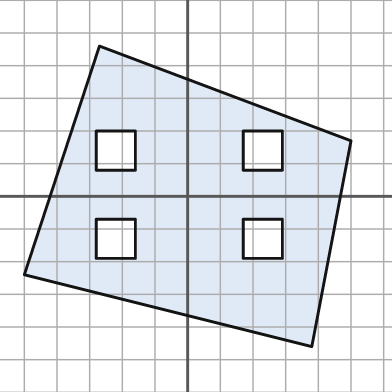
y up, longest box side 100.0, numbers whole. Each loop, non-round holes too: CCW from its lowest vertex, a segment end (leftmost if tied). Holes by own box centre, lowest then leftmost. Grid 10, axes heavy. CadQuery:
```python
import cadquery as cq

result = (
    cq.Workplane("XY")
    .moveTo(38.0, -46.0)
    .lineTo(50.0, 17.0)
    .lineTo(-27.0, 46.0)
    .lineTo(-50.0, -24.0)
    .close()
    .moveTo(-28.0, -19.0)
    .lineTo(-16.0, -19.0)
    .lineTo(-16.0, -7.0)
    .lineTo(-28.0, -7.0)
    .close()
    .moveTo(17.0, -19.0)
    .lineTo(29.0, -19.0)
    .lineTo(29.0, -7.0)
    .lineTo(17.0, -7.0)
    .close()
    .moveTo(-28.0, 8.0)
    .lineTo(-16.0, 8.0)
    .lineTo(-16.0, 20.0)
    .lineTo(-28.0, 20.0)
    .close()
    .moveTo(17.0, 8.0)
    .lineTo(29.0, 8.0)
    .lineTo(29.0, 20.0)
    .lineTo(17.0, 20.0)
    .close()
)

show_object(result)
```